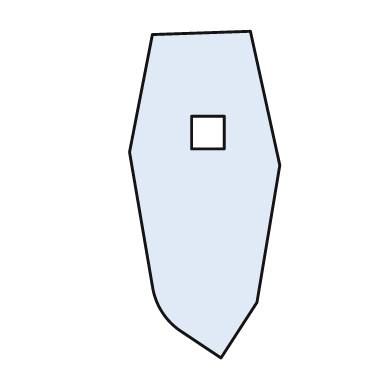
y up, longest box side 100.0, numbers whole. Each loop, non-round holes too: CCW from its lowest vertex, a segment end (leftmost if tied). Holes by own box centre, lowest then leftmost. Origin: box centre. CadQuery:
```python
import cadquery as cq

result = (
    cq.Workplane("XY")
    .moveTo(5.0, -50.0)
    .lineTo(16.0, -33.0)
    .lineTo(23.0, 9.0)
    .lineTo(14.0, 50.0)
    .lineTo(-16.0, 49.0)
    .lineTo(-23.0, 13.0)
    .lineTo(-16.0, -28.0)
    .threePointArc((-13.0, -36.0), (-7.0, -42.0))
    .close()
    .moveTo(-4.0, 14.0)
    .lineTo(6.0, 14.0)
    .lineTo(6.0, 24.0)
    .lineTo(-4.0, 24.0)
    .close()
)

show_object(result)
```